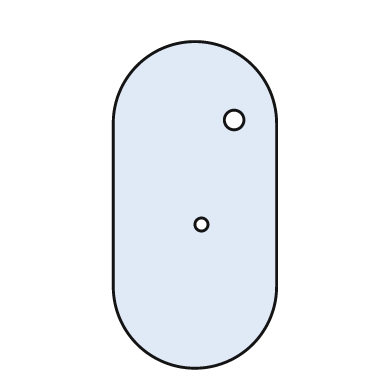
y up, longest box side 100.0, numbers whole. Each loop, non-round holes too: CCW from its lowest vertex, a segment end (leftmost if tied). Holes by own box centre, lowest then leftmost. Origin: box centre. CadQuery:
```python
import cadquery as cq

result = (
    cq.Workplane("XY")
    .moveTo(-25.0, -25.0)
    .threePointArc((0.0, -50.0), (25.0, -25.0))
    .lineTo(25.0, 25.0)
    .threePointArc((0.0, 50.0), (-25.0, 25.0))
    .close()
    .moveTo(2.0, -6.0)
    .circle(2.0)
    .moveTo(12.0, 26.0)
    .circle(3.0)
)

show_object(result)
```